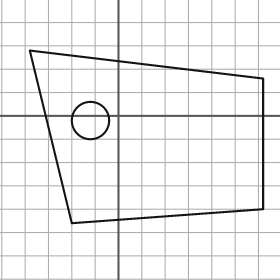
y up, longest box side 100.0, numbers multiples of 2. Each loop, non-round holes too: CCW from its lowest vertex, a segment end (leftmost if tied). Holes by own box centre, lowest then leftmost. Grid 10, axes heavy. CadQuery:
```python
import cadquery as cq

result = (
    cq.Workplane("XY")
    .moveTo(-20.0, -46.0)
    .lineTo(62.0, -40.0)
    .lineTo(62.0, 16.0)
    .lineTo(-38.0, 28.0)
    .close()
    .moveTo(-12.0, -2.0)
    .circle(8.0)
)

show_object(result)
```